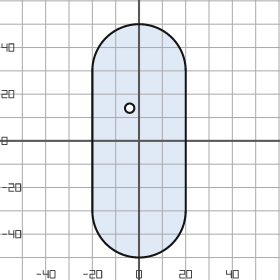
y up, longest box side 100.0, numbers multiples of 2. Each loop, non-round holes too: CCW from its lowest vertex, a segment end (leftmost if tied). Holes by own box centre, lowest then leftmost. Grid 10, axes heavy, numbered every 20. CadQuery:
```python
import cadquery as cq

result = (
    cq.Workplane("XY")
    .moveTo(-20.0, -30.0)
    .threePointArc((0.0, -50.0), (20.0, -30.0))
    .lineTo(20.0, 30.0)
    .threePointArc((0.0, 50.0), (-20.0, 30.0))
    .close()
    .moveTo(-4.0, 14.0)
    .circle(2.0)
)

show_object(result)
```